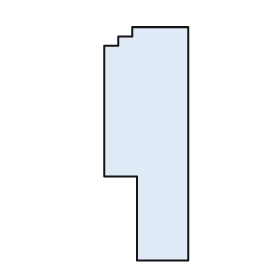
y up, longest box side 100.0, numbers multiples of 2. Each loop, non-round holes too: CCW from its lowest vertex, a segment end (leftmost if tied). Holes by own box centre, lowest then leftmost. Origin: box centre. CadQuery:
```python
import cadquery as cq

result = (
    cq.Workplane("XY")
    .moveTo(-4.0, -50.0)
    .lineTo(18.0, -50.0)
    .lineTo(18.0, 50.0)
    .lineTo(-6.0, 50.0)
    .lineTo(-6.0, 46.0)
    .lineTo(-12.0, 46.0)
    .lineTo(-12.0, 42.0)
    .lineTo(-18.0, 42.0)
    .lineTo(-18.0, -14.0)
    .lineTo(-4.0, -14.0)
    .close()
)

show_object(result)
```